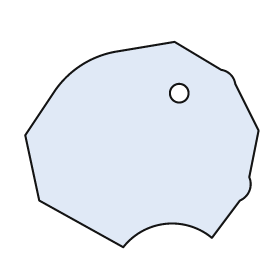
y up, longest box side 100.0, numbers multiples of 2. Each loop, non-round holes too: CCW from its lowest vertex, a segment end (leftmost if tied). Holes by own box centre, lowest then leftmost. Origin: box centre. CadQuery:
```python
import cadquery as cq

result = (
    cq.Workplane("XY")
    .moveTo(-8.0, -44.0)
    .threePointArc((10.0, -34.0), (30.0, -40.0))
    .lineTo(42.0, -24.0)
    .threePointArc((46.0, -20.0), (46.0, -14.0))
    .lineTo(50.0, 6.0)
    .lineTo(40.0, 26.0)
    .threePointArc((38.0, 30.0), (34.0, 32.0))
    .lineTo(14.0, 44.0)
    .lineTo(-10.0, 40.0)
    .threePointArc((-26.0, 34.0), (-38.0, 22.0))
    .lineTo(-50.0, 4.0)
    .lineTo(-44.0, -24.0)
    .close()
    .moveTo(16.0, 22.0)
    .circle(4.0)
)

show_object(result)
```